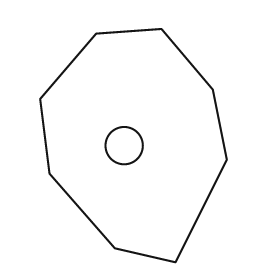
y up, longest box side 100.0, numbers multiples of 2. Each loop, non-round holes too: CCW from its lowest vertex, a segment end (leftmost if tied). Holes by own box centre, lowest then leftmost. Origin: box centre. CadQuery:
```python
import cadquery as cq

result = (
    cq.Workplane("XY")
    .moveTo(18.0, -50.0)
    .lineTo(40.0, -6.0)
    .lineTo(34.0, 24.0)
    .lineTo(12.0, 50.0)
    .lineTo(-16.0, 48.0)
    .lineTo(-40.0, 20.0)
    .lineTo(-36.0, -12.0)
    .lineTo(-8.0, -44.0)
    .close()
    .moveTo(-4.0, 0.0)
    .circle(8.0)
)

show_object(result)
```